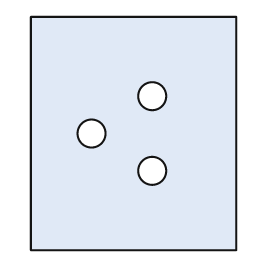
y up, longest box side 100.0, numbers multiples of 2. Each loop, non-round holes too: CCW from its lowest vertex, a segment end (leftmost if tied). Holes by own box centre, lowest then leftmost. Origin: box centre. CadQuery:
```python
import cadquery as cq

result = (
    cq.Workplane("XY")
    .moveTo(-44.0, -50.0)
    .lineTo(44.0, -50.0)
    .lineTo(44.0, 50.0)
    .lineTo(-44.0, 50.0)
    .close()
    .moveTo(8.0, -16.0)
    .circle(6.0)
    .moveTo(-18.0, 0.0)
    .circle(6.0)
    .moveTo(8.0, 16.0)
    .circle(6.0)
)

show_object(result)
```